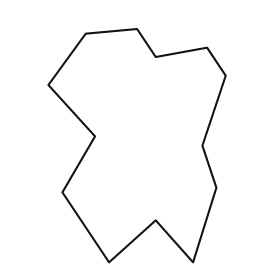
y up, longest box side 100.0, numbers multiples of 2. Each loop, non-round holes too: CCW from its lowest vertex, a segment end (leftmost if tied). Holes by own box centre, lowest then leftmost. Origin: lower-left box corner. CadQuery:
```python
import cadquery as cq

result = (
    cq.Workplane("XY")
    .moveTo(26.0, 0.0)
    .lineTo(46.0, 18.0)
    .lineTo(62.0, 0.0)
    .lineTo(72.0, 32.0)
    .lineTo(66.0, 50.0)
    .lineTo(76.0, 80.0)
    .lineTo(68.0, 92.0)
    .lineTo(46.0, 88.0)
    .lineTo(38.0, 100.0)
    .lineTo(16.0, 98.0)
    .lineTo(0.0, 76.0)
    .lineTo(20.0, 54.0)
    .lineTo(6.0, 30.0)
    .close()
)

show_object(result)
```